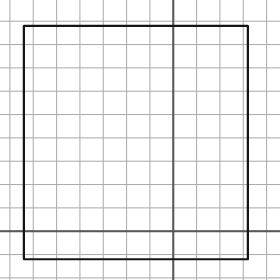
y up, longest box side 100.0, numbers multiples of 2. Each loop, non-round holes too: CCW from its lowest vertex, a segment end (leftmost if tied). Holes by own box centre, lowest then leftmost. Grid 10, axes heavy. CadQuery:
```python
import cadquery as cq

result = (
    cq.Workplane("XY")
    .moveTo(-64.0, -12.0)
    .lineTo(32.0, -12.0)
    .lineTo(32.0, 88.0)
    .lineTo(-64.0, 88.0)
    .close()
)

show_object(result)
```